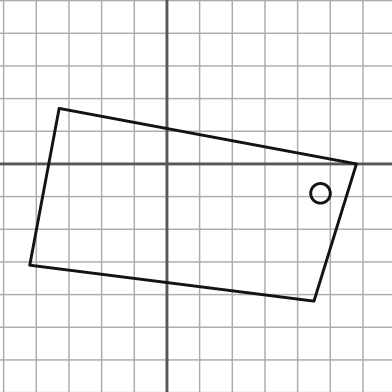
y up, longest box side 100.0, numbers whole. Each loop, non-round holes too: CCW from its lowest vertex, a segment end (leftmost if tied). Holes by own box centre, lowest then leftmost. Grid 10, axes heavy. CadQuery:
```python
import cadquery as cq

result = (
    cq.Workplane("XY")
    .moveTo(45.0, -42.0)
    .lineTo(58.0, 0.0)
    .lineTo(-33.0, 17.0)
    .lineTo(-42.0, -31.0)
    .close()
    .moveTo(47.0, -9.0)
    .circle(3.0)
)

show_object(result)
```